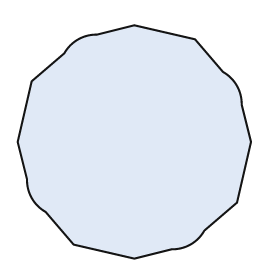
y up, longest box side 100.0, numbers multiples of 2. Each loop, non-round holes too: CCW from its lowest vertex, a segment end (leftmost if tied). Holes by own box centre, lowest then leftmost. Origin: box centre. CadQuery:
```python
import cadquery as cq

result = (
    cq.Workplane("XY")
    .moveTo(0.0, -50.0)
    .lineTo(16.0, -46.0)
    .threePointArc((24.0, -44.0), (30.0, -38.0))
    .lineTo(44.0, -26.0)
    .lineTo(50.0, 0.0)
    .lineTo(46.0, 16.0)
    .threePointArc((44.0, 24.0), (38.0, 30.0))
    .lineTo(26.0, 44.0)
    .lineTo(0.0, 50.0)
    .lineTo(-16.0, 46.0)
    .threePointArc((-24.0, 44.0), (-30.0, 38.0))
    .lineTo(-44.0, 26.0)
    .lineTo(-50.0, 0.0)
    .lineTo(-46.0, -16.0)
    .threePointArc((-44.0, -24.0), (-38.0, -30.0))
    .lineTo(-26.0, -44.0)
    .close()
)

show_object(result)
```